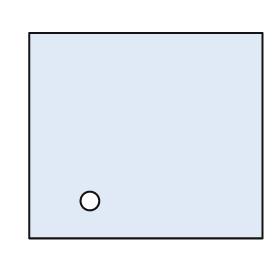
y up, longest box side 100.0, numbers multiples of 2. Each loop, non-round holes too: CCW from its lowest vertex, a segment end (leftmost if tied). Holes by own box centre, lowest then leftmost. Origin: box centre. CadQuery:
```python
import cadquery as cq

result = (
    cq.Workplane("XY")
    .moveTo(-50.0, -44.0)
    .lineTo(50.0, -44.0)
    .lineTo(50.0, 44.0)
    .lineTo(-50.0, 44.0)
    .close()
    .moveTo(-24.0, -28.0)
    .circle(4.0)
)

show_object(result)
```